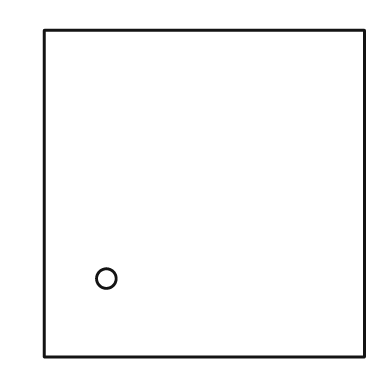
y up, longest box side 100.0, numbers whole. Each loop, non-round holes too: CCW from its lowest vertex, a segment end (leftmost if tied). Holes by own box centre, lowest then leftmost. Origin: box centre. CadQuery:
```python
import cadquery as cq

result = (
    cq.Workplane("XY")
    .moveTo(-49.0, -50.0)
    .lineTo(49.0, -50.0)
    .lineTo(49.0, 50.0)
    .lineTo(-49.0, 50.0)
    .close()
    .moveTo(-30.0, -26.0)
    .circle(3.0)
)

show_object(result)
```